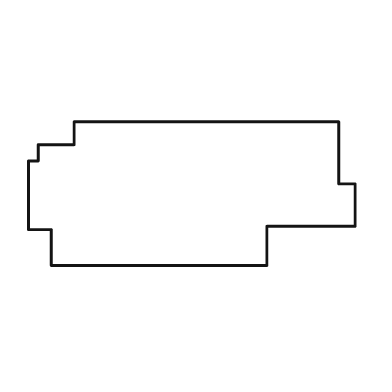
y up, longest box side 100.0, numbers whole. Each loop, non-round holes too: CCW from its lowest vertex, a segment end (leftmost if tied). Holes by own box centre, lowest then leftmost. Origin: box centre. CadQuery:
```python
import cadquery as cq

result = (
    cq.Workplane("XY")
    .moveTo(-43.0, -22.0)
    .lineTo(23.0, -22.0)
    .lineTo(23.0, -10.0)
    .lineTo(50.0, -10.0)
    .lineTo(50.0, 3.0)
    .lineTo(45.0, 3.0)
    .lineTo(45.0, 22.0)
    .lineTo(-36.0, 22.0)
    .lineTo(-36.0, 15.0)
    .lineTo(-47.0, 15.0)
    .lineTo(-47.0, 10.0)
    .lineTo(-50.0, 10.0)
    .lineTo(-50.0, -11.0)
    .lineTo(-43.0, -11.0)
    .close()
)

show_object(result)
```